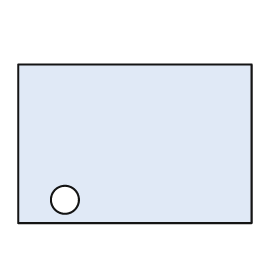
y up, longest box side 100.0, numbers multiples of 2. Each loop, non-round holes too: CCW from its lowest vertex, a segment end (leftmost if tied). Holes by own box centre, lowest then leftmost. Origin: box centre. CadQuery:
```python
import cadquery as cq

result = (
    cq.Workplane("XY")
    .moveTo(-50.0, -34.0)
    .lineTo(50.0, -34.0)
    .lineTo(50.0, 34.0)
    .lineTo(-50.0, 34.0)
    .close()
    .moveTo(-30.0, -24.0)
    .circle(6.0)
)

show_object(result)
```